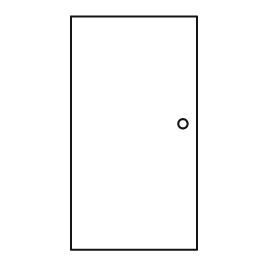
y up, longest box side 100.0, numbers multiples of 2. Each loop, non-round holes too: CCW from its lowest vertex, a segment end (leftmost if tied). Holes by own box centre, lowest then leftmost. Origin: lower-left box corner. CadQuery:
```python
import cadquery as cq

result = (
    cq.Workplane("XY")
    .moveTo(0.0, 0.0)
    .lineTo(54.0, 0.0)
    .lineTo(54.0, 100.0)
    .lineTo(0.0, 100.0)
    .close()
    .moveTo(48.0, 54.0)
    .circle(2.0)
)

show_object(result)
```